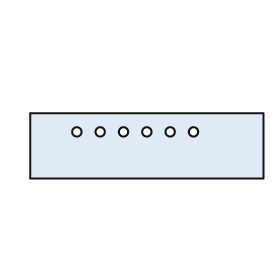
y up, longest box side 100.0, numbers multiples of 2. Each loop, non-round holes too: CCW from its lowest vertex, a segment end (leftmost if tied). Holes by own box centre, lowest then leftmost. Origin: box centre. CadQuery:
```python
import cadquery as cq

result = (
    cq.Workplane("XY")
    .moveTo(-50.0, -14.0)
    .lineTo(50.0, -14.0)
    .lineTo(50.0, 14.0)
    .lineTo(-50.0, 14.0)
    .close()
    .moveTo(-30.0, 6.0)
    .circle(2.0)
    .moveTo(-20.0, 6.0)
    .circle(2.0)
    .moveTo(-10.0, 6.0)
    .circle(2.0)
    .moveTo(0.0, 6.0)
    .circle(2.0)
    .moveTo(10.0, 6.0)
    .circle(2.0)
    .moveTo(20.0, 6.0)
    .circle(2.0)
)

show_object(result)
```